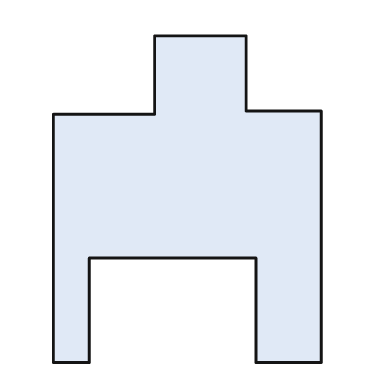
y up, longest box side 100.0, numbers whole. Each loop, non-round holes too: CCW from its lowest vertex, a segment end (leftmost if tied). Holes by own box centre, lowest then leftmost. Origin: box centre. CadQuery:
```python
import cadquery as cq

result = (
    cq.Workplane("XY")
    .moveTo(-41.0, -50.0)
    .lineTo(-30.0, -50.0)
    .lineTo(-30.0, -18.0)
    .lineTo(21.0, -18.0)
    .lineTo(21.0, -50.0)
    .lineTo(41.0, -50.0)
    .lineTo(41.0, 27.0)
    .lineTo(18.0, 27.0)
    .lineTo(18.0, 50.0)
    .lineTo(-10.0, 50.0)
    .lineTo(-10.0, 26.0)
    .lineTo(-41.0, 26.0)
    .close()
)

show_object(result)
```